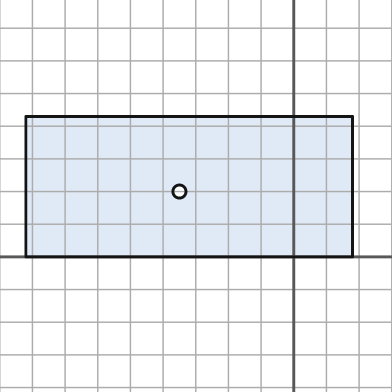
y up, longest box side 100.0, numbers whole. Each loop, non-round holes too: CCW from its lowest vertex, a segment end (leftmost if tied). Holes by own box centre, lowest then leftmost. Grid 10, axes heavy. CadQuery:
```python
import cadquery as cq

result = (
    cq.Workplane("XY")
    .moveTo(-82.0, 0.0)
    .lineTo(18.0, 0.0)
    .lineTo(18.0, 43.0)
    .lineTo(-82.0, 43.0)
    .close()
    .moveTo(-35.0, 20.0)
    .circle(2.0)
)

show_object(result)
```